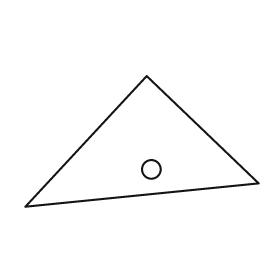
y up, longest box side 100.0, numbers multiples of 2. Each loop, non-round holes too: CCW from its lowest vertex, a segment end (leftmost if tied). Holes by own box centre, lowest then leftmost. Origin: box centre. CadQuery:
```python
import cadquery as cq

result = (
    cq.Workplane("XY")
    .moveTo(-50.0, -28.0)
    .lineTo(50.0, -18.0)
    .lineTo(2.0, 28.0)
    .close()
    .moveTo(4.0, -12.0)
    .circle(4.0)
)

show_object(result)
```